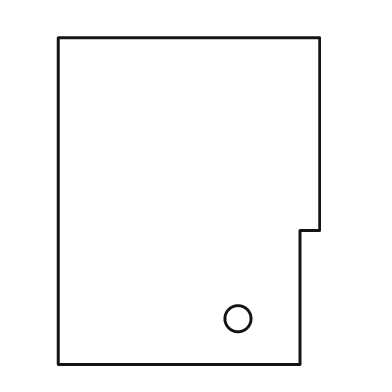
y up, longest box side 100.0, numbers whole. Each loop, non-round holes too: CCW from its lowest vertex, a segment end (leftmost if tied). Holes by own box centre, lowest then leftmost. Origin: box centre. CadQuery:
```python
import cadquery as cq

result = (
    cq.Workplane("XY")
    .moveTo(-40.0, -50.0)
    .lineTo(34.0, -50.0)
    .lineTo(34.0, -9.0)
    .lineTo(40.0, -9.0)
    .lineTo(40.0, 50.0)
    .lineTo(-40.0, 50.0)
    .close()
    .moveTo(15.0, -36.0)
    .circle(4.0)
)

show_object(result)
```